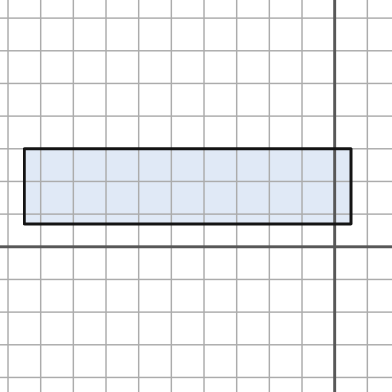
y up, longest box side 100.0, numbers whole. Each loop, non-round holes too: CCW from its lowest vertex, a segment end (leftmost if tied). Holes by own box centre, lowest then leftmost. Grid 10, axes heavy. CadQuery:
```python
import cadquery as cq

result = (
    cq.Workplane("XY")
    .moveTo(-95.0, 7.0)
    .lineTo(5.0, 7.0)
    .lineTo(5.0, 30.0)
    .lineTo(-95.0, 30.0)
    .close()
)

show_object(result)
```